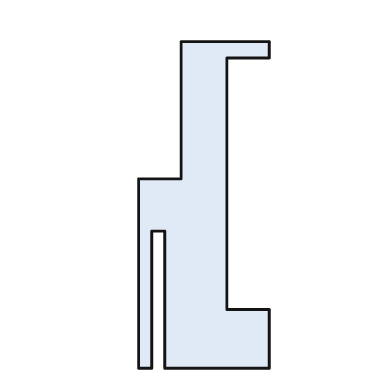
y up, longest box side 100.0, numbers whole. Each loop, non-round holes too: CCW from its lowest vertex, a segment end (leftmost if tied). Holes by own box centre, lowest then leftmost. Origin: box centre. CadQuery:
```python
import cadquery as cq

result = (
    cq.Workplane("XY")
    .moveTo(-20.0, -50.0)
    .lineTo(-16.0, -50.0)
    .lineTo(-16.0, -8.0)
    .lineTo(-12.0, -8.0)
    .lineTo(-12.0, -50.0)
    .lineTo(20.0, -50.0)
    .lineTo(20.0, -32.0)
    .lineTo(7.0, -32.0)
    .lineTo(7.0, 45.0)
    .lineTo(20.0, 45.0)
    .lineTo(20.0, 50.0)
    .lineTo(-7.0, 50.0)
    .lineTo(-7.0, 8.0)
    .lineTo(-20.0, 8.0)
    .close()
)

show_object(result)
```